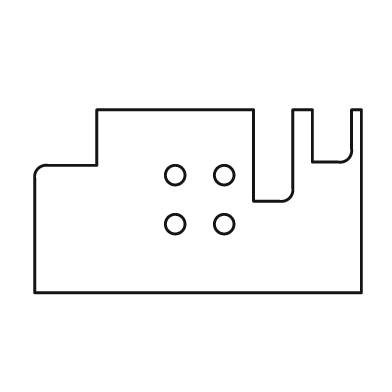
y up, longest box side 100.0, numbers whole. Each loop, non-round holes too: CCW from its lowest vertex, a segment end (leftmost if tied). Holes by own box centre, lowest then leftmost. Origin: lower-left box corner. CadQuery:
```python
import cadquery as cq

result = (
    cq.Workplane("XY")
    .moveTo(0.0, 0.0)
    .lineTo(100.0, 0.0)
    .lineTo(100.0, 56.0)
    .lineTo(97.0, 56.0)
    .lineTo(97.0, 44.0)
    .threePointArc((96.0, 41.0), (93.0, 40.0))
    .lineTo(85.0, 40.0)
    .lineTo(85.0, 56.0)
    .lineTo(79.0, 56.0)
    .lineTo(79.0, 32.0)
    .threePointArc((78.0, 29.0), (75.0, 28.0))
    .lineTo(67.0, 28.0)
    .lineTo(67.0, 56.0)
    .lineTo(19.0, 56.0)
    .lineTo(19.0, 39.0)
    .lineTo(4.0, 39.0)
    .threePointArc((1.0, 38.0), (0.0, 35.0))
    .close()
    .moveTo(43.0, 21.0)
    .circle(3.0)
    .moveTo(58.0, 21.0)
    .circle(3.0)
    .moveTo(43.0, 36.0)
    .circle(3.0)
    .moveTo(58.0, 36.0)
    .circle(3.0)
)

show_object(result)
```